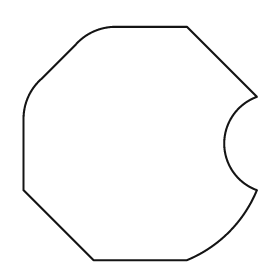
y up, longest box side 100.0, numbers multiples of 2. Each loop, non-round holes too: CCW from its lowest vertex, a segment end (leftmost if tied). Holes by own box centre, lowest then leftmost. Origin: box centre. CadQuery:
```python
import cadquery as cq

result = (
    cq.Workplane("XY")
    .moveTo(-20.0, -50.0)
    .lineTo(20.0, -50.0)
    .threePointArc((38.0, -38.0), (50.0, -20.0))
    .threePointArc((36.0, 0.0), (50.0, 20.0))
    .lineTo(20.0, 50.0)
    .lineTo(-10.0, 50.0)
    .threePointArc((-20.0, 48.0), (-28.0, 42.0))
    .lineTo(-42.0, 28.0)
    .threePointArc((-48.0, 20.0), (-50.0, 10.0))
    .lineTo(-50.0, -20.0)
    .close()
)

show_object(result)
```